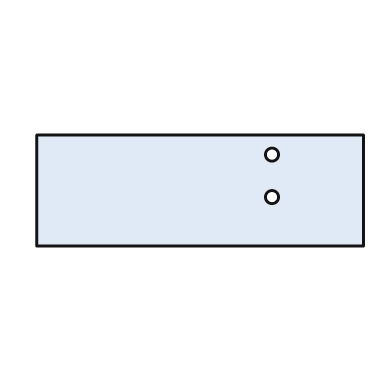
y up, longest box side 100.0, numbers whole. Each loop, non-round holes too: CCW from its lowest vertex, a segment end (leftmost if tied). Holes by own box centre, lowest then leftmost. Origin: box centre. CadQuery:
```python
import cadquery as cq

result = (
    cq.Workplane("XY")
    .moveTo(-50.0, -17.0)
    .lineTo(50.0, -17.0)
    .lineTo(50.0, 17.0)
    .lineTo(-50.0, 17.0)
    .close()
    .moveTo(22.0, -2.0)
    .circle(2.0)
    .moveTo(22.0, 11.0)
    .circle(2.0)
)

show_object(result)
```